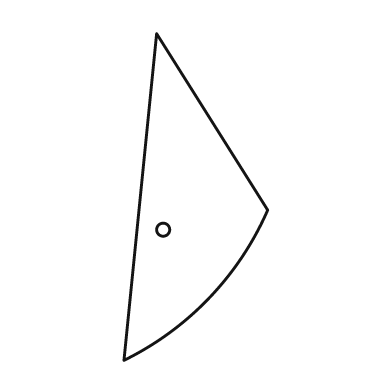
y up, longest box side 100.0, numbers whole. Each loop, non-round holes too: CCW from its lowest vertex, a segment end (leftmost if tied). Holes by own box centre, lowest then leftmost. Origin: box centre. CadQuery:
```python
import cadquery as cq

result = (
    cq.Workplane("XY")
    .moveTo(-22.0, -50.0)
    .threePointArc((4.0, -31.0), (22.0, -4.0))
    .lineTo(-12.0, 50.0)
    .close()
    .moveTo(-10.0, -10.0)
    .circle(2.0)
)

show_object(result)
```